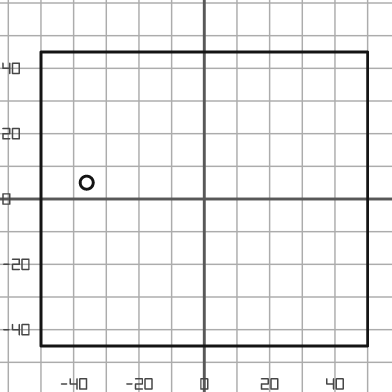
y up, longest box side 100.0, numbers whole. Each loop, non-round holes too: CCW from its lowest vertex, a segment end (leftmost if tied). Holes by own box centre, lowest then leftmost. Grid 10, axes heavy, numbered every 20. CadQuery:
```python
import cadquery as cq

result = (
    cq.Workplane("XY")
    .moveTo(-50.0, -45.0)
    .lineTo(50.0, -45.0)
    .lineTo(50.0, 45.0)
    .lineTo(-50.0, 45.0)
    .close()
    .moveTo(-36.0, 5.0)
    .circle(2.0)
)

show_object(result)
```